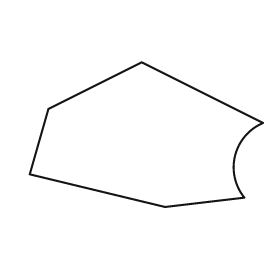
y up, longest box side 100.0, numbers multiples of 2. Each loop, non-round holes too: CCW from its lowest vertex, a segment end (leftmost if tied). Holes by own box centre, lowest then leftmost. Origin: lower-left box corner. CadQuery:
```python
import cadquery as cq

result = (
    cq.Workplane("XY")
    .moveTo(58.0, 0.0)
    .lineTo(92.0, 4.0)
    .threePointArc((88.0, 22.0), (100.0, 36.0))
    .lineTo(48.0, 62.0)
    .lineTo(8.0, 42.0)
    .lineTo(0.0, 14.0)
    .close()
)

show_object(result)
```